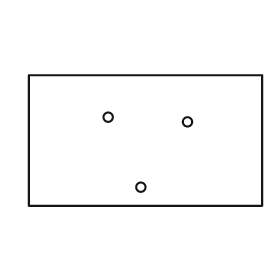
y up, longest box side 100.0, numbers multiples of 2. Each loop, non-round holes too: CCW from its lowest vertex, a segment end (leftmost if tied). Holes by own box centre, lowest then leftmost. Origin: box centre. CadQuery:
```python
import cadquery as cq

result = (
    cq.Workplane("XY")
    .moveTo(-50.0, -28.0)
    .lineTo(50.0, -28.0)
    .lineTo(50.0, 28.0)
    .lineTo(-50.0, 28.0)
    .close()
    .moveTo(-2.0, -20.0)
    .circle(2.0)
    .moveTo(18.0, 8.0)
    .circle(2.0)
    .moveTo(-16.0, 10.0)
    .circle(2.0)
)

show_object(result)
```